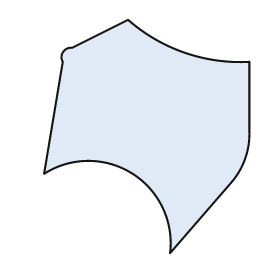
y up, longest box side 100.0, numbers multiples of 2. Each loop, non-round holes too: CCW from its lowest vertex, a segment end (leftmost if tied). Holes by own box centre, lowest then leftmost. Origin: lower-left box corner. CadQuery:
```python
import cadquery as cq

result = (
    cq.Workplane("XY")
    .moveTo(54.0, 0.0)
    .lineTo(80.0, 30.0)
    .threePointArc((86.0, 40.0), (88.0, 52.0))
    .lineTo(88.0, 82.0)
    .threePointArc((60.0, 86.0), (36.0, 100.0))
    .lineTo(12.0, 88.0)
    .threePointArc((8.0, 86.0), (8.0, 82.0))
    .lineTo(0.0, 34.0)
    .threePointArc((38.0, 34.0), (54.0, 0.0))
    .close()
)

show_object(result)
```